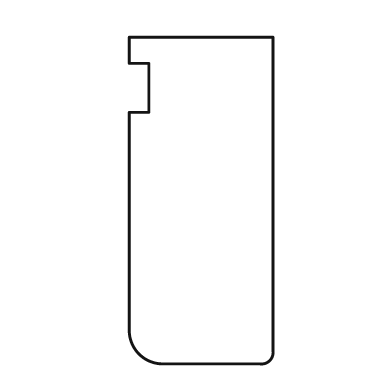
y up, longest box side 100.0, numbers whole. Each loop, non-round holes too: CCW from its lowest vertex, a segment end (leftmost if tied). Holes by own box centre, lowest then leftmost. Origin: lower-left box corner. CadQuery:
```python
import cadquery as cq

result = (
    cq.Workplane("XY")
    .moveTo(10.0, 0.0)
    .lineTo(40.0, 0.0)
    .threePointArc((43.0, 1.0), (44.0, 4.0))
    .lineTo(44.0, 100.0)
    .lineTo(0.0, 100.0)
    .lineTo(0.0, 92.0)
    .lineTo(6.0, 92.0)
    .lineTo(6.0, 77.0)
    .lineTo(0.0, 77.0)
    .lineTo(0.0, 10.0)
    .threePointArc((3.0, 3.0), (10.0, 0.0))
    .close()
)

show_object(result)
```